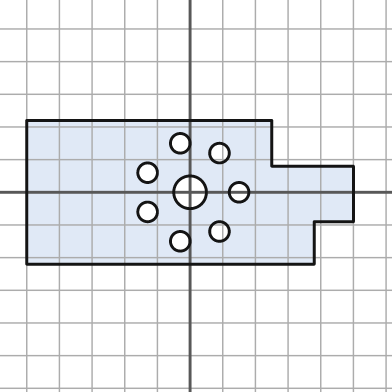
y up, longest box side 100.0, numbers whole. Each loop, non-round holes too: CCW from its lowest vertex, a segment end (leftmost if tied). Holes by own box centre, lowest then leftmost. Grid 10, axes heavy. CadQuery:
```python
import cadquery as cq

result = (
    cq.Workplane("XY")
    .moveTo(-50.0, -22.0)
    .lineTo(38.0, -22.0)
    .lineTo(38.0, -9.0)
    .lineTo(50.0, -9.0)
    .lineTo(50.0, 8.0)
    .lineTo(25.0, 8.0)
    .lineTo(25.0, 22.0)
    .lineTo(-50.0, 22.0)
    .close()
    .moveTo(-3.0, -15.0)
    .circle(3.0)
    .moveTo(9.0, -12.0)
    .circle(3.0)
    .moveTo(-13.0, -6.0)
    .circle(3.0)
    .moveTo(0.0, 0.0)
    .circle(5.0)
    .moveTo(15.0, 0.0)
    .circle(3.0)
    .moveTo(-13.0, 6.0)
    .circle(3.0)
    .moveTo(9.0, 12.0)
    .circle(3.0)
    .moveTo(-3.0, 15.0)
    .circle(3.0)
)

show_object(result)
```